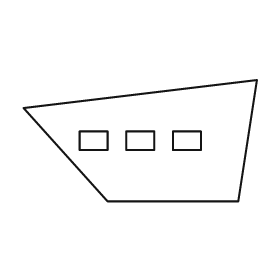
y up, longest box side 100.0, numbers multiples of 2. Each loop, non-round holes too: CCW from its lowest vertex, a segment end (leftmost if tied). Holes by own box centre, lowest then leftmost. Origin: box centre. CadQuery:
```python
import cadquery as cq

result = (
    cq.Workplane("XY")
    .moveTo(-14.0, -26.0)
    .lineTo(42.0, -26.0)
    .lineTo(50.0, 26.0)
    .lineTo(-50.0, 14.0)
    .close()
    .moveTo(-26.0, -4.0)
    .lineTo(-14.0, -4.0)
    .lineTo(-14.0, 4.0)
    .lineTo(-26.0, 4.0)
    .close()
    .moveTo(-6.0, -4.0)
    .lineTo(6.0, -4.0)
    .lineTo(6.0, 4.0)
    .lineTo(-6.0, 4.0)
    .close()
    .moveTo(14.0, -4.0)
    .lineTo(26.0, -4.0)
    .lineTo(26.0, 4.0)
    .lineTo(14.0, 4.0)
    .close()
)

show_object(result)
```